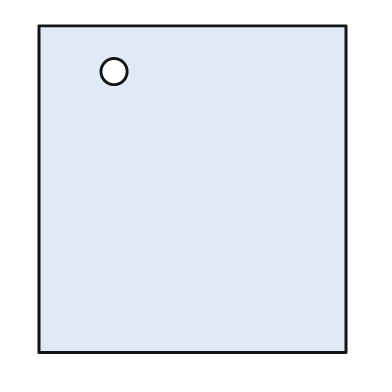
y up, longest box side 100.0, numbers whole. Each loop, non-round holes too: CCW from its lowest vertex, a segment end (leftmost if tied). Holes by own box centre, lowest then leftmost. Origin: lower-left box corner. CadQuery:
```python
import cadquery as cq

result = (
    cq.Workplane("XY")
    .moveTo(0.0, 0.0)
    .lineTo(94.0, 0.0)
    .lineTo(94.0, 100.0)
    .lineTo(0.0, 100.0)
    .close()
    .moveTo(23.0, 86.0)
    .circle(4.0)
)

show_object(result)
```